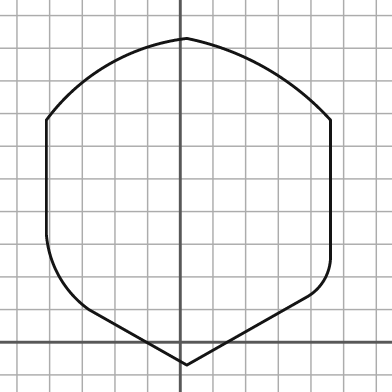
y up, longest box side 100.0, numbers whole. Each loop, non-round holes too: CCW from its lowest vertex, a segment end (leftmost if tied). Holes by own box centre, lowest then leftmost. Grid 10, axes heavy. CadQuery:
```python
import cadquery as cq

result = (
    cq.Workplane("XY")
    .moveTo(2.0, -7.0)
    .lineTo(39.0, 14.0)
    .threePointArc((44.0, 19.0), (46.0, 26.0))
    .lineTo(46.0, 68.0)
    .threePointArc((26.0, 84.0), (2.0, 93.0))
    .threePointArc((-22.0, 85.0), (-41.0, 68.0))
    .lineTo(-41.0, 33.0)
    .threePointArc((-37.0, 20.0), (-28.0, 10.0))
    .close()
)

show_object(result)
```